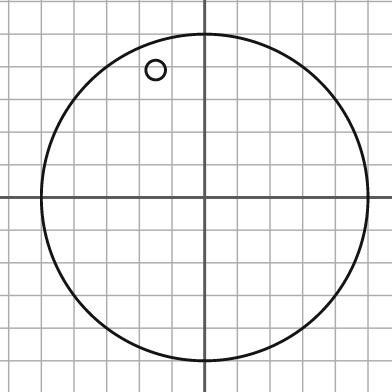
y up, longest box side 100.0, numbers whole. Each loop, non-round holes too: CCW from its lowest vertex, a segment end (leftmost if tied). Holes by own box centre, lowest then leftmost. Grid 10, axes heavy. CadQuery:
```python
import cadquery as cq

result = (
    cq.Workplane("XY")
    .moveTo(0.0, 0.0)
    .circle(50.0)
    .moveTo(-15.0, 39.0)
    .circle(3.0)
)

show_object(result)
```